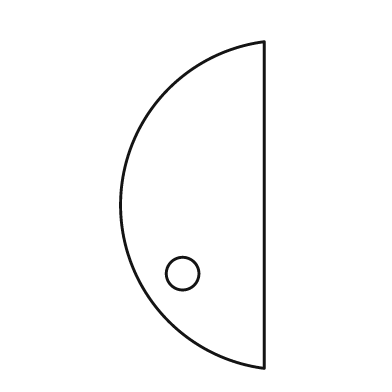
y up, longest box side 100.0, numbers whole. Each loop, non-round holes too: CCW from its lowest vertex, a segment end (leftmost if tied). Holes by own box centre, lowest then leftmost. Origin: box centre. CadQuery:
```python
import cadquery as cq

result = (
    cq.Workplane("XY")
    .moveTo(22.0, -50.0)
    .lineTo(22.0, 50.0)
    .threePointArc((-22.0, 0.0), (22.0, -50.0))
    .close()
    .moveTo(-3.0, -21.0)
    .circle(5.0)
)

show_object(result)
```